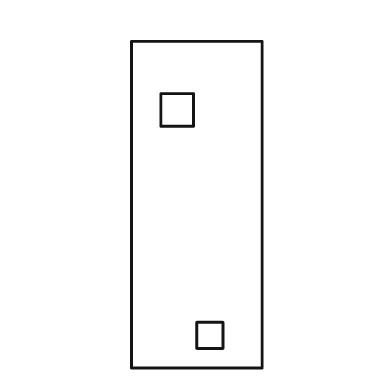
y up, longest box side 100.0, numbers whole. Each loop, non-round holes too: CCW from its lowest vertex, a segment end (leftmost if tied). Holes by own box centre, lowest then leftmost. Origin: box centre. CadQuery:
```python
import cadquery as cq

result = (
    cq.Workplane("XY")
    .moveTo(-20.0, -50.0)
    .lineTo(20.0, -50.0)
    .lineTo(20.0, 50.0)
    .lineTo(-20.0, 50.0)
    .close()
    .moveTo(0.0, -44.0)
    .lineTo(8.0, -44.0)
    .lineTo(8.0, -36.0)
    .lineTo(0.0, -36.0)
    .close()
    .moveTo(-11.0, 24.0)
    .lineTo(-1.0, 24.0)
    .lineTo(-1.0, 34.0)
    .lineTo(-11.0, 34.0)
    .close()
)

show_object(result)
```